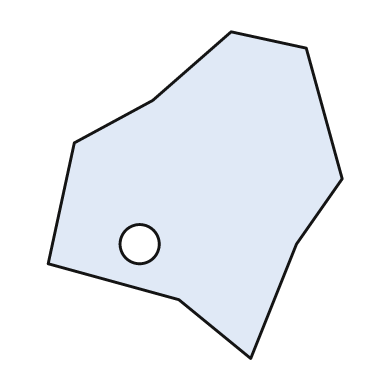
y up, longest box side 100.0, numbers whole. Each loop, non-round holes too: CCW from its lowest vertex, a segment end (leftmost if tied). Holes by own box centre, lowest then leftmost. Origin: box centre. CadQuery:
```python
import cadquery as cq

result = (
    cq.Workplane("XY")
    .moveTo(17.0, -50.0)
    .lineTo(31.0, -15.0)
    .lineTo(45.0, 5.0)
    .lineTo(34.0, 45.0)
    .lineTo(11.0, 50.0)
    .lineTo(-13.0, 29.0)
    .lineTo(-37.0, 16.0)
    .lineTo(-45.0, -21.0)
    .lineTo(-5.0, -32.0)
    .close()
    .moveTo(-17.0, -15.0)
    .circle(6.0)
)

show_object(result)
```